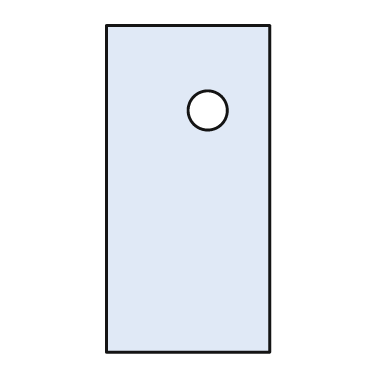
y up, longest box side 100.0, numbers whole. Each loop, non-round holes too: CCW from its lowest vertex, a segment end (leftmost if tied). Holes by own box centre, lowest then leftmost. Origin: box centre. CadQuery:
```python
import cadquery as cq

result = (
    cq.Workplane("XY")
    .moveTo(-25.0, -50.0)
    .lineTo(25.0, -50.0)
    .lineTo(25.0, 50.0)
    .lineTo(-25.0, 50.0)
    .close()
    .moveTo(6.0, 24.0)
    .circle(6.0)
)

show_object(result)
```